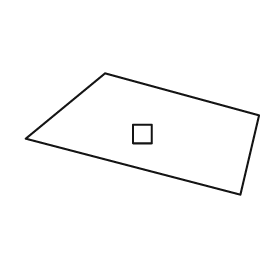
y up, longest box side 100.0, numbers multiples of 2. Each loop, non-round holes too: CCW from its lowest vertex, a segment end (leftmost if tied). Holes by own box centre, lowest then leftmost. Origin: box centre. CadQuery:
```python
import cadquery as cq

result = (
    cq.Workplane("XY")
    .moveTo(42.0, -26.0)
    .lineTo(50.0, 8.0)
    .lineTo(-16.0, 26.0)
    .lineTo(-50.0, -2.0)
    .close()
    .moveTo(-4.0, -4.0)
    .lineTo(4.0, -4.0)
    .lineTo(4.0, 4.0)
    .lineTo(-4.0, 4.0)
    .close()
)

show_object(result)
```